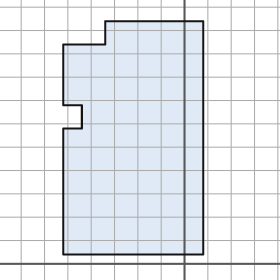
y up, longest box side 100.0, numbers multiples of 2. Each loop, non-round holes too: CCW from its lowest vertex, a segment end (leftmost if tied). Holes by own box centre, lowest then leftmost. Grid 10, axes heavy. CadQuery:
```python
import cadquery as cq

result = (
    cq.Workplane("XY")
    .moveTo(-52.0, 4.0)
    .lineTo(8.0, 4.0)
    .lineTo(8.0, 104.0)
    .lineTo(-34.0, 104.0)
    .lineTo(-34.0, 94.0)
    .lineTo(-52.0, 94.0)
    .lineTo(-52.0, 68.0)
    .lineTo(-44.0, 68.0)
    .lineTo(-44.0, 58.0)
    .lineTo(-52.0, 58.0)
    .close()
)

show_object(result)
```